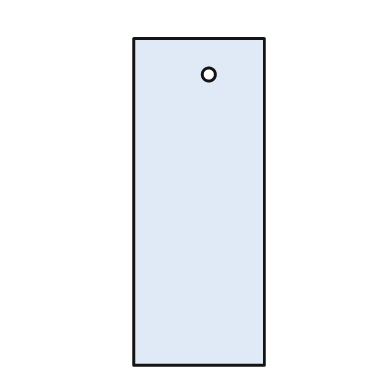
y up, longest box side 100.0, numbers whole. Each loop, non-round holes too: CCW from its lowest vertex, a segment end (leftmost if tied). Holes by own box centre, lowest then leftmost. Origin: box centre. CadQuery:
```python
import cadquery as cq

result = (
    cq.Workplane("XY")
    .moveTo(-20.0, -50.0)
    .lineTo(20.0, -50.0)
    .lineTo(20.0, 50.0)
    .lineTo(-20.0, 50.0)
    .close()
    .moveTo(3.0, 39.0)
    .circle(2.0)
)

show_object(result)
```